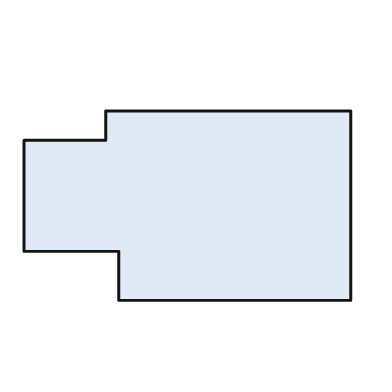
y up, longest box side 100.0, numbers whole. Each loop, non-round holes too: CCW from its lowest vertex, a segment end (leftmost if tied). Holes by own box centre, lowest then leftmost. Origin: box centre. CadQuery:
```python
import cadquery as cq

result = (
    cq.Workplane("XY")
    .moveTo(-21.0, -29.0)
    .lineTo(50.0, -29.0)
    .lineTo(50.0, 29.0)
    .lineTo(-25.0, 29.0)
    .lineTo(-25.0, 20.0)
    .lineTo(-50.0, 20.0)
    .lineTo(-50.0, -14.0)
    .lineTo(-21.0, -14.0)
    .close()
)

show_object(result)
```